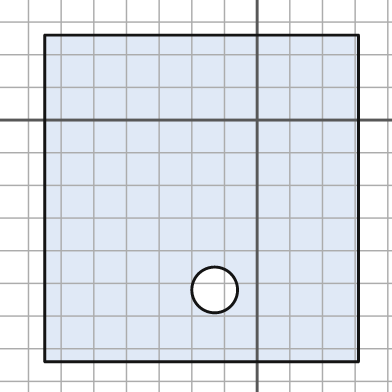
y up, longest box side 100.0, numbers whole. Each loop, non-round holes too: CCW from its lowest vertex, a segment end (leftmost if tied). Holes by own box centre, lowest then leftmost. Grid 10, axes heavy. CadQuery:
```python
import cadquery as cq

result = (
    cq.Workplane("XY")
    .moveTo(-65.0, -74.0)
    .lineTo(31.0, -74.0)
    .lineTo(31.0, 26.0)
    .lineTo(-65.0, 26.0)
    .close()
    .moveTo(-13.0, -52.0)
    .circle(7.0)
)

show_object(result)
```